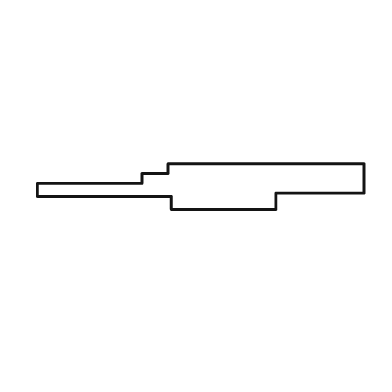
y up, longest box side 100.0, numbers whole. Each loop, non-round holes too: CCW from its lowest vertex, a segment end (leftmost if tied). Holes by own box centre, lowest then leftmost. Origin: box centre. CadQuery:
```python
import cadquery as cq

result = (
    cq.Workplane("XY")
    .moveTo(-9.0, -7.0)
    .lineTo(23.0, -7.0)
    .lineTo(23.0, -2.0)
    .lineTo(50.0, -2.0)
    .lineTo(50.0, 7.0)
    .lineTo(-10.0, 7.0)
    .lineTo(-10.0, 4.0)
    .lineTo(-18.0, 4.0)
    .lineTo(-18.0, 1.0)
    .lineTo(-50.0, 1.0)
    .lineTo(-50.0, -3.0)
    .lineTo(-9.0, -3.0)
    .close()
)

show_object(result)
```